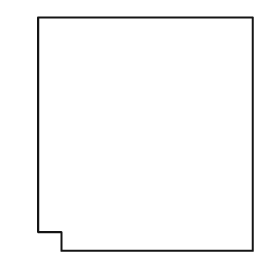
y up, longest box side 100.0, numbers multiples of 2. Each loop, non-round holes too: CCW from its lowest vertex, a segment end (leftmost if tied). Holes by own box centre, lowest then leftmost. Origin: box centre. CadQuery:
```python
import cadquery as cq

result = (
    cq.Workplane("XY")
    .moveTo(-36.0, -50.0)
    .lineTo(46.0, -50.0)
    .lineTo(46.0, 50.0)
    .lineTo(-46.0, 50.0)
    .lineTo(-46.0, -42.0)
    .lineTo(-36.0, -42.0)
    .close()
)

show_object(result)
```